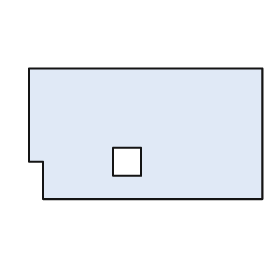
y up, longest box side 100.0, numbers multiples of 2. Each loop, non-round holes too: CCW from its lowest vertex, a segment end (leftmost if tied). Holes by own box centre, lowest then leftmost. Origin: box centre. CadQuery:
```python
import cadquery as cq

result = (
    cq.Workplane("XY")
    .moveTo(-44.0, -28.0)
    .lineTo(50.0, -28.0)
    .lineTo(50.0, 28.0)
    .lineTo(-50.0, 28.0)
    .lineTo(-50.0, -12.0)
    .lineTo(-44.0, -12.0)
    .close()
    .moveTo(-14.0, -18.0)
    .lineTo(-2.0, -18.0)
    .lineTo(-2.0, -6.0)
    .lineTo(-14.0, -6.0)
    .close()
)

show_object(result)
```